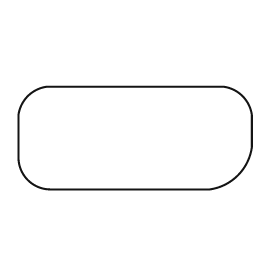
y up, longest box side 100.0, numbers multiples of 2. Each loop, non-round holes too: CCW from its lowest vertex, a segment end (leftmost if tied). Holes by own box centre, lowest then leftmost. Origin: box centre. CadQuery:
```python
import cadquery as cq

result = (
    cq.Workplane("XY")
    .moveTo(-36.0, -22.0)
    .lineTo(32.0, -22.0)
    .threePointArc((44.0, -16.0), (50.0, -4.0))
    .lineTo(50.0, 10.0)
    .threePointArc((46.0, 18.0), (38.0, 22.0))
    .lineTo(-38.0, 22.0)
    .threePointArc((-46.0, 18.0), (-50.0, 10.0))
    .lineTo(-50.0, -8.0)
    .threePointArc((-46.0, -18.0), (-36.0, -22.0))
    .close()
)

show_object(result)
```